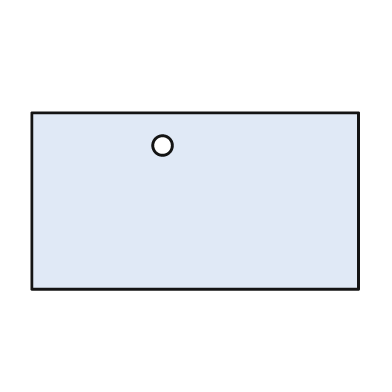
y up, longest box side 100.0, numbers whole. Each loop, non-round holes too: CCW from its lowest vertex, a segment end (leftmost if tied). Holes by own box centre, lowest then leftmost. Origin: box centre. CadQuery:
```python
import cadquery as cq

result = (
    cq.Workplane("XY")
    .moveTo(-50.0, -27.0)
    .lineTo(50.0, -27.0)
    .lineTo(50.0, 27.0)
    .lineTo(-50.0, 27.0)
    .close()
    .moveTo(-10.0, 17.0)
    .circle(3.0)
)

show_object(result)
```